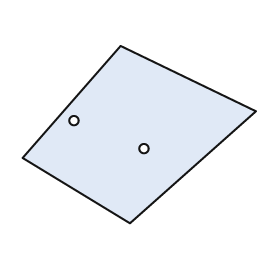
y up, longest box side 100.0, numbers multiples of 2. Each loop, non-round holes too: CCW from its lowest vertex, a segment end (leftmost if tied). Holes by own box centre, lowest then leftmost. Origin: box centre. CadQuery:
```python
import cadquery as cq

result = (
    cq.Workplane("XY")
    .moveTo(-4.0, -38.0)
    .lineTo(50.0, 10.0)
    .lineTo(-8.0, 38.0)
    .lineTo(-50.0, -10.0)
    .close()
    .moveTo(2.0, -6.0)
    .circle(2.0)
    .moveTo(-28.0, 6.0)
    .circle(2.0)
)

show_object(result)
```